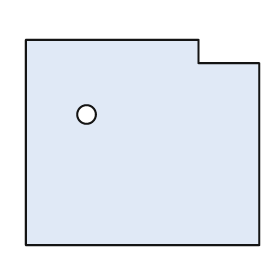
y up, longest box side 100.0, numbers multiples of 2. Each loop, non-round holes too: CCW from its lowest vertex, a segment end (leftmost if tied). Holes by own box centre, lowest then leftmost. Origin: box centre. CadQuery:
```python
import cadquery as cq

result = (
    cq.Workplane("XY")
    .moveTo(-50.0, -44.0)
    .lineTo(50.0, -44.0)
    .lineTo(50.0, 34.0)
    .lineTo(24.0, 34.0)
    .lineTo(24.0, 44.0)
    .lineTo(-50.0, 44.0)
    .close()
    .moveTo(-24.0, 12.0)
    .circle(4.0)
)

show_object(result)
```